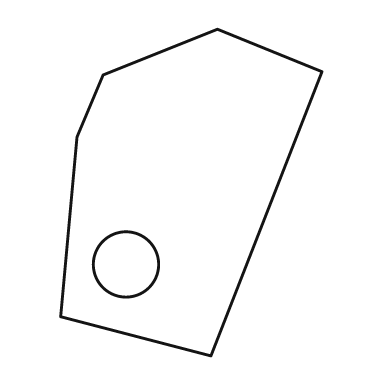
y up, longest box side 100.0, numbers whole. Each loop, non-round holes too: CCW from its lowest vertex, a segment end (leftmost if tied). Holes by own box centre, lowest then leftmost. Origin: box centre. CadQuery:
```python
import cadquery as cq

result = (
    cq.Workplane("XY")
    .moveTo(6.0, -50.0)
    .lineTo(40.0, 37.0)
    .lineTo(8.0, 50.0)
    .lineTo(-27.0, 36.0)
    .lineTo(-35.0, 17.0)
    .lineTo(-40.0, -38.0)
    .close()
    .moveTo(-20.0, -22.0)
    .circle(10.0)
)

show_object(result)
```